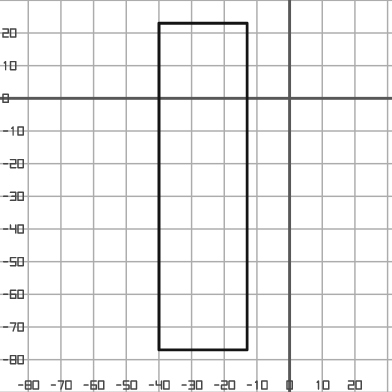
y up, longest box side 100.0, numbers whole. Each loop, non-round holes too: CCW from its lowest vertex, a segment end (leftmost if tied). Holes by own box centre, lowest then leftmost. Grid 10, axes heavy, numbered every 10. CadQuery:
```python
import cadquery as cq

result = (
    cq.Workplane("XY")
    .moveTo(-40.0, -77.0)
    .lineTo(-13.0, -77.0)
    .lineTo(-13.0, 23.0)
    .lineTo(-40.0, 23.0)
    .close()
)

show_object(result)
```